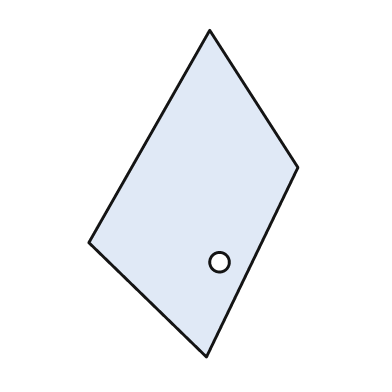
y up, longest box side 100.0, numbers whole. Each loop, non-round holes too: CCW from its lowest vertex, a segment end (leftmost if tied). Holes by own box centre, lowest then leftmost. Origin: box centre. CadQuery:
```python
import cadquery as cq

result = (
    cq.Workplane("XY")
    .moveTo(4.0, -50.0)
    .lineTo(32.0, 8.0)
    .lineTo(5.0, 50.0)
    .lineTo(-32.0, -15.0)
    .close()
    .moveTo(8.0, -21.0)
    .circle(3.0)
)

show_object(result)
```